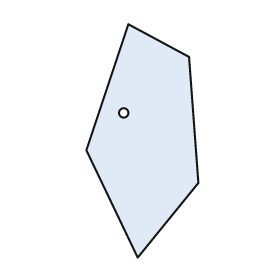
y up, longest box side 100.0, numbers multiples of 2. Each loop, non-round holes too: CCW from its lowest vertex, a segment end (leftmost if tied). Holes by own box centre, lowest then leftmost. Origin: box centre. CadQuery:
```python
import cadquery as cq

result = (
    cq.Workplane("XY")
    .moveTo(-2.0, -50.0)
    .lineTo(24.0, -18.0)
    .lineTo(20.0, 36.0)
    .lineTo(-6.0, 50.0)
    .lineTo(-24.0, -4.0)
    .close()
    .moveTo(-8.0, 12.0)
    .circle(2.0)
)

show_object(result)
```